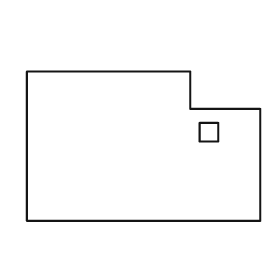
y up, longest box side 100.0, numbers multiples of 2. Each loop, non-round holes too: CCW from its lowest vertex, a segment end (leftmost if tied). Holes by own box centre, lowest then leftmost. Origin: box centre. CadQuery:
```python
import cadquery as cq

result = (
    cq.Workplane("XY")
    .moveTo(-50.0, -32.0)
    .lineTo(50.0, -32.0)
    .lineTo(50.0, 16.0)
    .lineTo(20.0, 16.0)
    .lineTo(20.0, 32.0)
    .lineTo(-50.0, 32.0)
    .close()
    .moveTo(24.0, 2.0)
    .lineTo(32.0, 2.0)
    .lineTo(32.0, 10.0)
    .lineTo(24.0, 10.0)
    .close()
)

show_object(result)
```